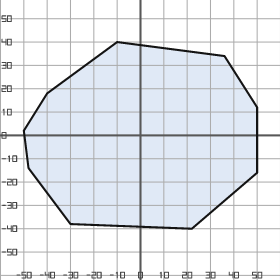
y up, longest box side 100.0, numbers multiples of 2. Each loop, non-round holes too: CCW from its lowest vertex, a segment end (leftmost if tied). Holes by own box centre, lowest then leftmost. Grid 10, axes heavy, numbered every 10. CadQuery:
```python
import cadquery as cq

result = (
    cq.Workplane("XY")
    .moveTo(22.0, -40.0)
    .lineTo(50.0, -16.0)
    .lineTo(50.0, 12.0)
    .lineTo(36.0, 34.0)
    .lineTo(-10.0, 40.0)
    .lineTo(-40.0, 18.0)
    .lineTo(-50.0, 2.0)
    .lineTo(-48.0, -14.0)
    .lineTo(-30.0, -38.0)
    .close()
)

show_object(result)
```